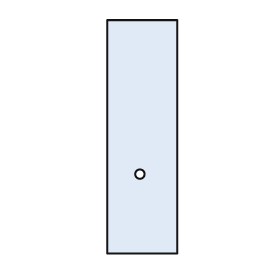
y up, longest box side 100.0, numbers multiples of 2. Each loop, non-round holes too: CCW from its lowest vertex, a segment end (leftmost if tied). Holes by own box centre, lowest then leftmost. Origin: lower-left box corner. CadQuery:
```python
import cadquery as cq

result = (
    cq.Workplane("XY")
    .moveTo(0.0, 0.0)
    .lineTo(30.0, 0.0)
    .lineTo(30.0, 100.0)
    .lineTo(0.0, 100.0)
    .close()
    .moveTo(14.0, 34.0)
    .circle(2.0)
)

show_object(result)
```